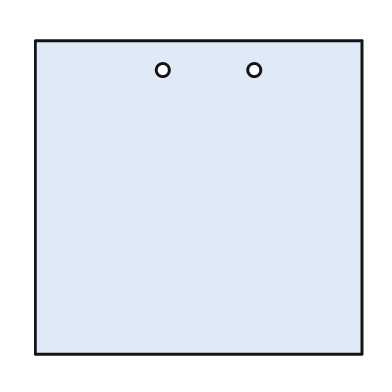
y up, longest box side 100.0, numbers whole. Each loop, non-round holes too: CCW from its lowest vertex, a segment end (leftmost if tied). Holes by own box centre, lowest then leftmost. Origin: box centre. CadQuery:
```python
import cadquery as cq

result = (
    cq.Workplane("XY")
    .moveTo(-50.0, -48.0)
    .lineTo(50.0, -48.0)
    .lineTo(50.0, 48.0)
    .lineTo(-50.0, 48.0)
    .close()
    .moveTo(-11.0, 39.0)
    .circle(2.0)
    .moveTo(17.0, 39.0)
    .circle(2.0)
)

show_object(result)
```